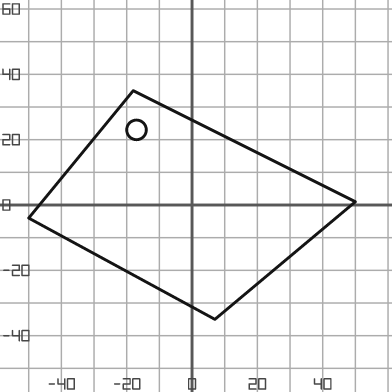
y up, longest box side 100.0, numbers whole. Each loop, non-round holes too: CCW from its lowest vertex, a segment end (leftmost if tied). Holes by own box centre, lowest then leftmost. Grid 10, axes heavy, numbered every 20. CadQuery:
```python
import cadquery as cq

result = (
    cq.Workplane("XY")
    .moveTo(7.0, -35.0)
    .lineTo(50.0, 1.0)
    .lineTo(-18.0, 35.0)
    .lineTo(-50.0, -4.0)
    .close()
    .moveTo(-17.0, 23.0)
    .circle(3.0)
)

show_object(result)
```